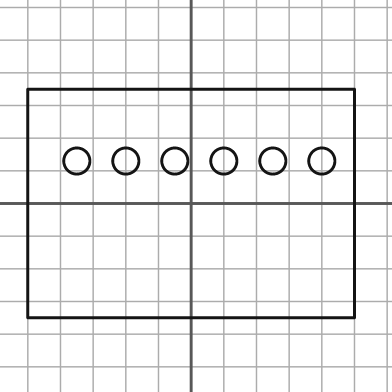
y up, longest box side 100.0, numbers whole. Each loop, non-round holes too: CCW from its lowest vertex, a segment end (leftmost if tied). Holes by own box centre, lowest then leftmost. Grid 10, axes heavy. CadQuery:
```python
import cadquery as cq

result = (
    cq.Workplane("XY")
    .moveTo(-50.0, -35.0)
    .lineTo(50.0, -35.0)
    .lineTo(50.0, 35.0)
    .lineTo(-50.0, 35.0)
    .close()
    .moveTo(-35.0, 13.0)
    .circle(4.0)
    .moveTo(-20.0, 13.0)
    .circle(4.0)
    .moveTo(-5.0, 13.0)
    .circle(4.0)
    .moveTo(10.0, 13.0)
    .circle(4.0)
    .moveTo(25.0, 13.0)
    .circle(4.0)
    .moveTo(40.0, 13.0)
    .circle(4.0)
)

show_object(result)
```